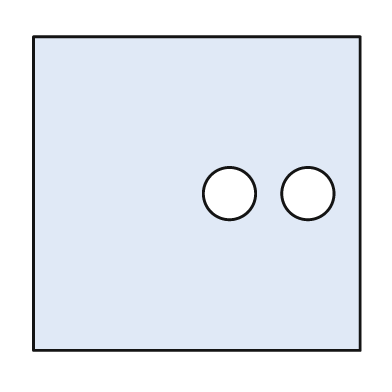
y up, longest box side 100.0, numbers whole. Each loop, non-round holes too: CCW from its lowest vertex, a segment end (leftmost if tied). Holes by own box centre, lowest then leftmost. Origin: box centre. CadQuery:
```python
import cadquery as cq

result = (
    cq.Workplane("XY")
    .moveTo(-50.0, -48.0)
    .lineTo(50.0, -48.0)
    .lineTo(50.0, 48.0)
    .lineTo(-50.0, 48.0)
    .close()
    .moveTo(10.0, 0.0)
    .circle(8.0)
    .moveTo(34.0, 0.0)
    .circle(8.0)
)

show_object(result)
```